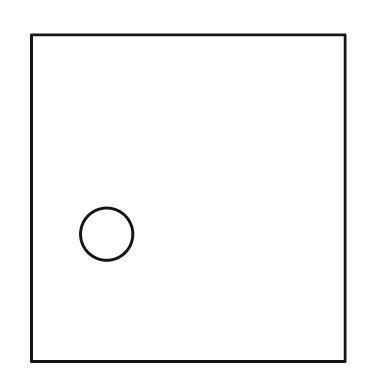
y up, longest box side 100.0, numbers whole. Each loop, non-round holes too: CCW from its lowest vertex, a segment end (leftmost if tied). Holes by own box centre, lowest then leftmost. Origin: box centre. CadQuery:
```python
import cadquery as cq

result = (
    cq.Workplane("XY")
    .moveTo(-48.0, -50.0)
    .lineTo(48.0, -50.0)
    .lineTo(48.0, 50.0)
    .lineTo(-48.0, 50.0)
    .close()
    .moveTo(-25.0, -11.0)
    .circle(8.0)
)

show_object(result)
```